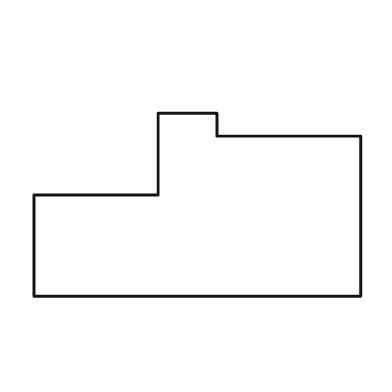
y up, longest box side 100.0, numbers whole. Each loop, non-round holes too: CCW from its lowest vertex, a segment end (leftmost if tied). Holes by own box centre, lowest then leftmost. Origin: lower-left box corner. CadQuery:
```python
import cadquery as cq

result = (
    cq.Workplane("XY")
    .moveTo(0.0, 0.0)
    .lineTo(100.0, 0.0)
    .lineTo(100.0, 49.0)
    .lineTo(56.0, 49.0)
    .lineTo(56.0, 56.0)
    .lineTo(38.0, 56.0)
    .lineTo(38.0, 31.0)
    .lineTo(0.0, 31.0)
    .close()
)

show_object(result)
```